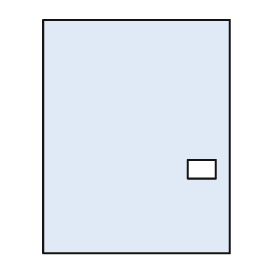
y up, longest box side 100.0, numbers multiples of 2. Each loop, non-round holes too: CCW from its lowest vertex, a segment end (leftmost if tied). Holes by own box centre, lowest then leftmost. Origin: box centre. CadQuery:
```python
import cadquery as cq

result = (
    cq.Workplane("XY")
    .moveTo(-40.0, -50.0)
    .lineTo(40.0, -50.0)
    .lineTo(40.0, 50.0)
    .lineTo(-40.0, 50.0)
    .close()
    .moveTo(22.0, -18.0)
    .lineTo(34.0, -18.0)
    .lineTo(34.0, -10.0)
    .lineTo(22.0, -10.0)
    .close()
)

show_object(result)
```